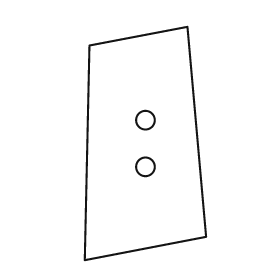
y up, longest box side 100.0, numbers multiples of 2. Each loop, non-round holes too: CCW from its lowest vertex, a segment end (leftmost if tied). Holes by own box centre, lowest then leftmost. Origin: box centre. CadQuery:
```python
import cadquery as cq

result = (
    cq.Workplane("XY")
    .moveTo(-26.0, -50.0)
    .lineTo(26.0, -40.0)
    .lineTo(18.0, 50.0)
    .lineTo(-24.0, 42.0)
    .close()
    .moveTo(0.0, -10.0)
    .circle(4.0)
    .moveTo(0.0, 10.0)
    .circle(4.0)
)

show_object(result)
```